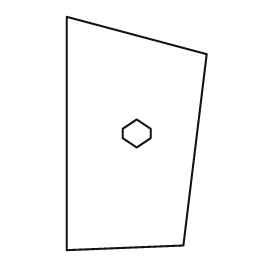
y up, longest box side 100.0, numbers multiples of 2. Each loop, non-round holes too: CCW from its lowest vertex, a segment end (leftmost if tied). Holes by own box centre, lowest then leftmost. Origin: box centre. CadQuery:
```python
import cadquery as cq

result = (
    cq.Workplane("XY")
    .moveTo(-30.0, -50.0)
    .lineTo(20.0, -48.0)
    .lineTo(30.0, 34.0)
    .lineTo(-30.0, 50.0)
    .close()
    .moveTo(0.0, -6.0)
    .lineTo(6.0, -2.0)
    .lineTo(6.0, 2.0)
    .lineTo(0.0, 6.0)
    .lineTo(-6.0, 2.0)
    .lineTo(-6.0, -2.0)
    .close()
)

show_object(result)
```